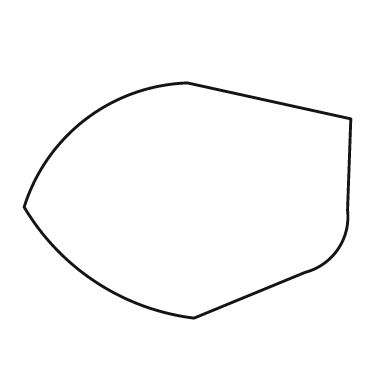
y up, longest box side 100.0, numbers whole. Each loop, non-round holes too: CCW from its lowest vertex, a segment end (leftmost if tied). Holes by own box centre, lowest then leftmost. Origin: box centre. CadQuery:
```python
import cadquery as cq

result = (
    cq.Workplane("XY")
    .moveTo(2.0, -36.0)
    .lineTo(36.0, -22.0)
    .threePointArc((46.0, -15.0), (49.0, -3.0))
    .lineTo(50.0, 25.0)
    .lineTo(0.0, 36.0)
    .threePointArc((-31.0, 25.0), (-50.0, -2.0))
    .threePointArc((-28.0, -25.0), (2.0, -36.0))
    .close()
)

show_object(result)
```